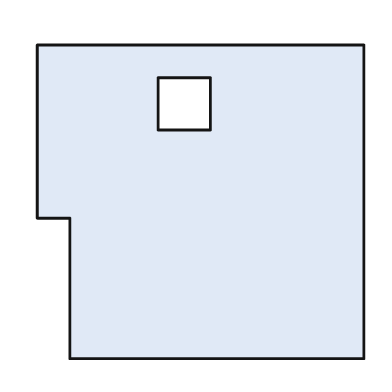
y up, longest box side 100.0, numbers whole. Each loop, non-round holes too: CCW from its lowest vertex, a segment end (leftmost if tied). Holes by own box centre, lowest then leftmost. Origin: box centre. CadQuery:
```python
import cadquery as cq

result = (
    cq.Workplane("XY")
    .moveTo(-40.0, -48.0)
    .lineTo(50.0, -48.0)
    .lineTo(50.0, 48.0)
    .lineTo(-50.0, 48.0)
    .lineTo(-50.0, -5.0)
    .lineTo(-40.0, -5.0)
    .close()
    .moveTo(-13.0, 22.0)
    .lineTo(3.0, 22.0)
    .lineTo(3.0, 38.0)
    .lineTo(-13.0, 38.0)
    .close()
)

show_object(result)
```